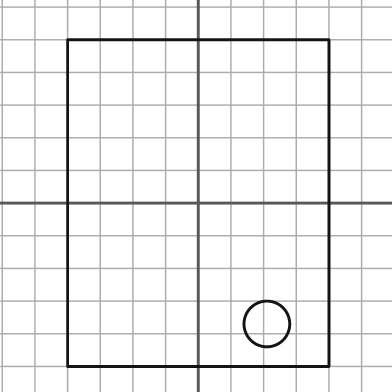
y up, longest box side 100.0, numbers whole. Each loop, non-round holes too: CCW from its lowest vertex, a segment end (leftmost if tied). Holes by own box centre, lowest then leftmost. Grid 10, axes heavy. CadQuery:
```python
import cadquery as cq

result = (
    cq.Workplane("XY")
    .moveTo(-40.0, -50.0)
    .lineTo(40.0, -50.0)
    .lineTo(40.0, 50.0)
    .lineTo(-40.0, 50.0)
    .close()
    .moveTo(21.0, -37.0)
    .circle(7.0)
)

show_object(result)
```